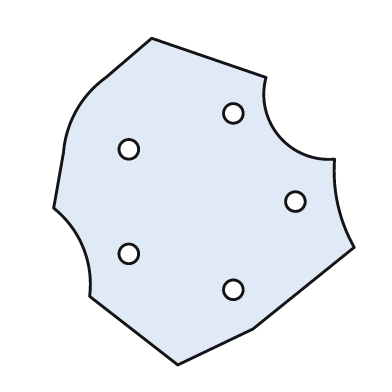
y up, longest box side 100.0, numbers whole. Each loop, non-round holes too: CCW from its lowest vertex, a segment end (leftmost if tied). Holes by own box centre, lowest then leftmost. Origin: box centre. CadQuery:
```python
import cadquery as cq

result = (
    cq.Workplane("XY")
    .moveTo(-8.0, -50.0)
    .lineTo(15.0, -39.0)
    .lineTo(46.0, -14.0)
    .threePointArc((41.0, -1.0), (40.0, 13.0))
    .threePointArc((23.0, 20.0), (19.0, 38.0))
    .lineTo(-16.0, 50.0)
    .lineTo(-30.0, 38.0)
    .threePointArc((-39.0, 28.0), (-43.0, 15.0))
    .lineTo(-46.0, -2.0)
    .threePointArc((-37.0, -14.0), (-35.0, -29.0))
    .close()
    .moveTo(9.0, -27.0)
    .circle(3.0)
    .moveTo(-23.0, -16.0)
    .circle(3.0)
    .moveTo(28.0, 0.0)
    .circle(3.0)
    .moveTo(-23.0, 16.0)
    .circle(3.0)
    .moveTo(9.0, 27.0)
    .circle(3.0)
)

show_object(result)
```